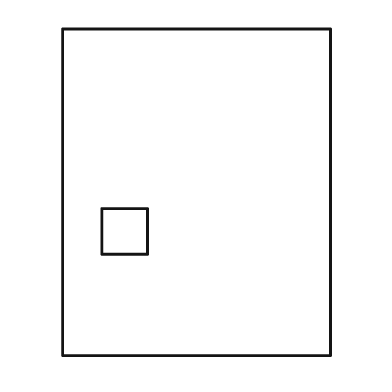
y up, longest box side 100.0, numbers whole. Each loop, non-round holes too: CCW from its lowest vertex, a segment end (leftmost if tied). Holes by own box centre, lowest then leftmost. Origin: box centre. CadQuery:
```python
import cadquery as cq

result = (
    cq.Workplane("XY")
    .moveTo(-41.0, -50.0)
    .lineTo(41.0, -50.0)
    .lineTo(41.0, 50.0)
    .lineTo(-41.0, 50.0)
    .close()
    .moveTo(-29.0, -19.0)
    .lineTo(-15.0, -19.0)
    .lineTo(-15.0, -5.0)
    .lineTo(-29.0, -5.0)
    .close()
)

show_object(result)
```